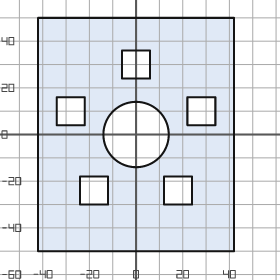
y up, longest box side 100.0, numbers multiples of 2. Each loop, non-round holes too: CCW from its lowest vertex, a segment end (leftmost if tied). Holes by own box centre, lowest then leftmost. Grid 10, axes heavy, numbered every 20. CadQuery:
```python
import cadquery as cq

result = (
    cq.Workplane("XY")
    .moveTo(-42.0, -50.0)
    .lineTo(42.0, -50.0)
    .lineTo(42.0, 50.0)
    .lineTo(-42.0, 50.0)
    .close()
    .moveTo(-24.0, -30.0)
    .lineTo(-12.0, -30.0)
    .lineTo(-12.0, -18.0)
    .lineTo(-24.0, -18.0)
    .close()
    .moveTo(12.0, -30.0)
    .lineTo(24.0, -30.0)
    .lineTo(24.0, -18.0)
    .lineTo(12.0, -18.0)
    .close()
    .moveTo(0.0, 0.0)
    .circle(14.0)
    .moveTo(-34.0, 4.0)
    .lineTo(-22.0, 4.0)
    .lineTo(-22.0, 16.0)
    .lineTo(-34.0, 16.0)
    .close()
    .moveTo(22.0, 4.0)
    .lineTo(34.0, 4.0)
    .lineTo(34.0, 16.0)
    .lineTo(22.0, 16.0)
    .close()
    .moveTo(-6.0, 24.0)
    .lineTo(6.0, 24.0)
    .lineTo(6.0, 36.0)
    .lineTo(-6.0, 36.0)
    .close()
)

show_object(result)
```